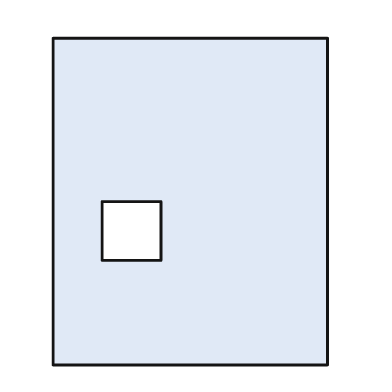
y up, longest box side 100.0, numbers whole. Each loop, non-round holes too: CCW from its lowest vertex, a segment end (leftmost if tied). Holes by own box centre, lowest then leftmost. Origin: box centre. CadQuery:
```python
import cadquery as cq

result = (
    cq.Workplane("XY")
    .moveTo(-42.0, -50.0)
    .lineTo(42.0, -50.0)
    .lineTo(42.0, 50.0)
    .lineTo(-42.0, 50.0)
    .close()
    .moveTo(-27.0, -18.0)
    .lineTo(-9.0, -18.0)
    .lineTo(-9.0, 0.0)
    .lineTo(-27.0, 0.0)
    .close()
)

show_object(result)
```